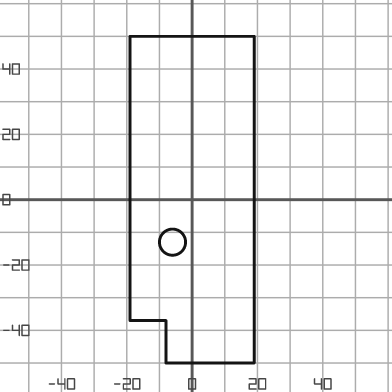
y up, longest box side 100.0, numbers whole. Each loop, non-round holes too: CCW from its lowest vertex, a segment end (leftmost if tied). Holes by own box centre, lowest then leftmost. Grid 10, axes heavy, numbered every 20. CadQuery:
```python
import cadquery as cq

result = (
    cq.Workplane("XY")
    .moveTo(-8.0, -50.0)
    .lineTo(19.0, -50.0)
    .lineTo(19.0, 50.0)
    .lineTo(-19.0, 50.0)
    .lineTo(-19.0, -37.0)
    .lineTo(-8.0, -37.0)
    .close()
    .moveTo(-6.0, -13.0)
    .circle(4.0)
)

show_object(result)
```